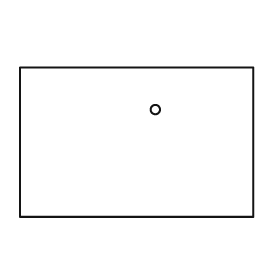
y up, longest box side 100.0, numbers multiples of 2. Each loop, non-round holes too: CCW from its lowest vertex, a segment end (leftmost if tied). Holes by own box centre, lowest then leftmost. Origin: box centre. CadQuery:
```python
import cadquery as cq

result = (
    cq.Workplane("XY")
    .moveTo(-50.0, -32.0)
    .lineTo(50.0, -32.0)
    .lineTo(50.0, 32.0)
    .lineTo(-50.0, 32.0)
    .close()
    .moveTo(8.0, 14.0)
    .circle(2.0)
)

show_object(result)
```